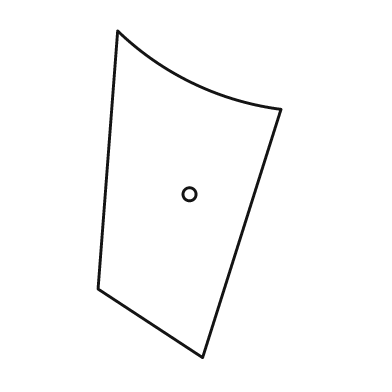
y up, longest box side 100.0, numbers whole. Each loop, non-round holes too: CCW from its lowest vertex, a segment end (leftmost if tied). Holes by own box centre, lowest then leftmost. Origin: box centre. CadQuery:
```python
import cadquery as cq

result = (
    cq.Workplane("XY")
    .moveTo(4.0, -50.0)
    .lineTo(28.0, 26.0)
    .threePointArc((1.0, 34.0), (-22.0, 50.0))
    .lineTo(-28.0, -29.0)
    .close()
    .moveTo(0.0, 0.0)
    .circle(2.0)
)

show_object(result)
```